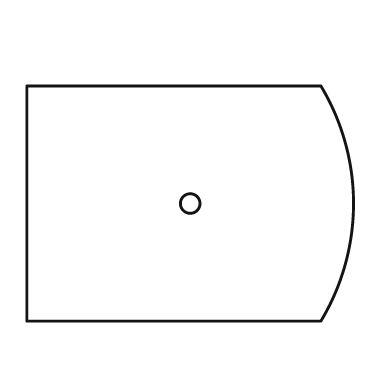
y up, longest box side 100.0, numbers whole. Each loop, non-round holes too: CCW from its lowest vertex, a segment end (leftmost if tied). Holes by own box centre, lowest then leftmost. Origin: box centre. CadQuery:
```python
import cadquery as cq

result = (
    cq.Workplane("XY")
    .moveTo(-50.0, -36.0)
    .lineTo(40.0, -36.0)
    .threePointArc((50.0, 0.0), (40.0, 36.0))
    .lineTo(-50.0, 36.0)
    .close()
    .moveTo(0.0, 0.0)
    .circle(3.0)
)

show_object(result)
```